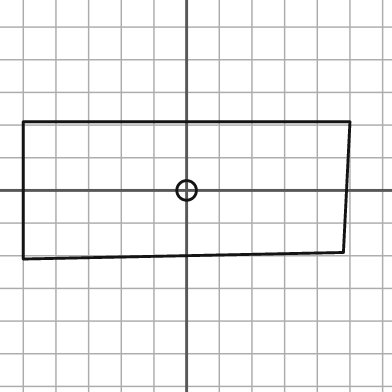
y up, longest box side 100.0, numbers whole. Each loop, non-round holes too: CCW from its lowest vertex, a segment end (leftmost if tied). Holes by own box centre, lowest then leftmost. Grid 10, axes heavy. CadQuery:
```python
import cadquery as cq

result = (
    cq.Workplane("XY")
    .moveTo(-50.0, -21.0)
    .lineTo(48.0, -19.0)
    .lineTo(50.0, 21.0)
    .lineTo(-50.0, 21.0)
    .close()
    .moveTo(0.0, 0.0)
    .circle(3.0)
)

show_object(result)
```